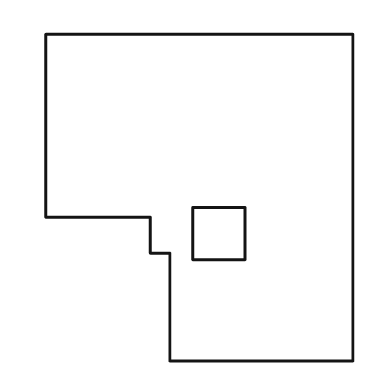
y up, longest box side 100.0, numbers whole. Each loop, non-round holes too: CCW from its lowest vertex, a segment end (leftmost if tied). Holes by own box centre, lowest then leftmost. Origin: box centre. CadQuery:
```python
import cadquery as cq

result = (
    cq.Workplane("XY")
    .moveTo(-9.0, -50.0)
    .lineTo(47.0, -50.0)
    .lineTo(47.0, 50.0)
    .lineTo(-47.0, 50.0)
    .lineTo(-47.0, -6.0)
    .lineTo(-15.0, -6.0)
    .lineTo(-15.0, -17.0)
    .lineTo(-9.0, -17.0)
    .close()
    .moveTo(-2.0, -19.0)
    .lineTo(14.0, -19.0)
    .lineTo(14.0, -3.0)
    .lineTo(-2.0, -3.0)
    .close()
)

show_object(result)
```